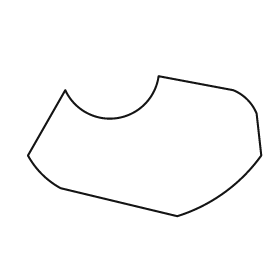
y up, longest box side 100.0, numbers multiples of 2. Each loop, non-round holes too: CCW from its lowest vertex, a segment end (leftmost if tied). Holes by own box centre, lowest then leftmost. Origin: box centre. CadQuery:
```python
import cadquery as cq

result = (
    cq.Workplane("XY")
    .moveTo(14.0, -30.0)
    .threePointArc((34.0, -20.0), (50.0, -4.0))
    .lineTo(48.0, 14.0)
    .threePointArc((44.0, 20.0), (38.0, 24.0))
    .lineTo(6.0, 30.0)
    .threePointArc((-12.0, 12.0), (-34.0, 24.0))
    .lineTo(-50.0, -4.0)
    .threePointArc((-44.0, -12.0), (-36.0, -18.0))
    .close()
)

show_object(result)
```